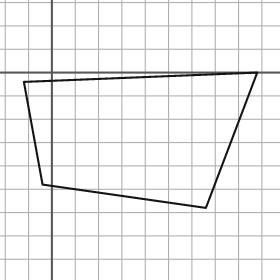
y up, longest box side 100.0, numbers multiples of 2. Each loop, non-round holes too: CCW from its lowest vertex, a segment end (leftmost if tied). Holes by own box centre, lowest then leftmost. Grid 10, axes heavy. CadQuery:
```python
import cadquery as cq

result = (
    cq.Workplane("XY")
    .moveTo(66.0, -58.0)
    .lineTo(88.0, 0.0)
    .lineTo(-12.0, -4.0)
    .lineTo(-4.0, -48.0)
    .close()
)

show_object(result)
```